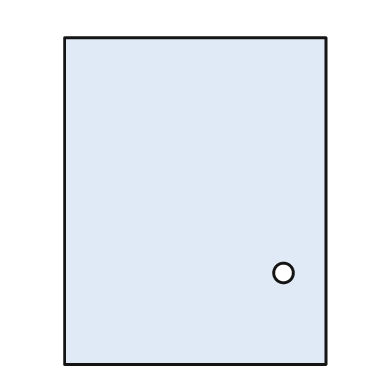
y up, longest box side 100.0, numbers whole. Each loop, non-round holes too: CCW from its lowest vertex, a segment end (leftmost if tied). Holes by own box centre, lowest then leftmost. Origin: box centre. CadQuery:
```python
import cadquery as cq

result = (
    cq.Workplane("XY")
    .moveTo(-40.0, -50.0)
    .lineTo(40.0, -50.0)
    .lineTo(40.0, 50.0)
    .lineTo(-40.0, 50.0)
    .close()
    .moveTo(27.0, -22.0)
    .circle(3.0)
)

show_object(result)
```